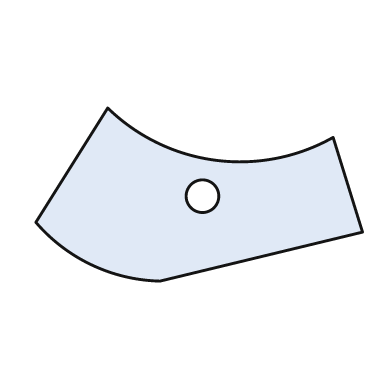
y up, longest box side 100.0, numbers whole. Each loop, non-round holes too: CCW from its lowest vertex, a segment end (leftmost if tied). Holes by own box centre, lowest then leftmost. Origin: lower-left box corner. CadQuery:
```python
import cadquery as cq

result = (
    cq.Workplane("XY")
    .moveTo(38.0, 0.0)
    .lineTo(100.0, 15.0)
    .lineTo(91.0, 44.0)
    .threePointArc((55.0, 37.0), (22.0, 53.0))
    .lineTo(0.0, 18.0)
    .threePointArc((17.0, 5.0), (38.0, 0.0))
    .close()
    .moveTo(51.0, 26.0)
    .circle(5.0)
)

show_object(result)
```